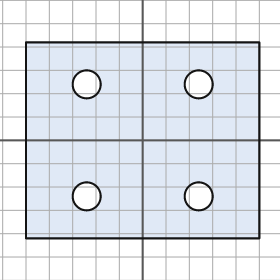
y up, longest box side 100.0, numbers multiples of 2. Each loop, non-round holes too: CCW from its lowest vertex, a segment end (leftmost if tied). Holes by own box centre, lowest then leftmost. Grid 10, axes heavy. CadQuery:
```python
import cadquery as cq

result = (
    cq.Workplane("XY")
    .moveTo(-50.0, -42.0)
    .lineTo(50.0, -42.0)
    .lineTo(50.0, 42.0)
    .lineTo(-50.0, 42.0)
    .close()
    .moveTo(-24.0, -24.0)
    .circle(6.0)
    .moveTo(24.0, -24.0)
    .circle(6.0)
    .moveTo(-24.0, 24.0)
    .circle(6.0)
    .moveTo(24.0, 24.0)
    .circle(6.0)
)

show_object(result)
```